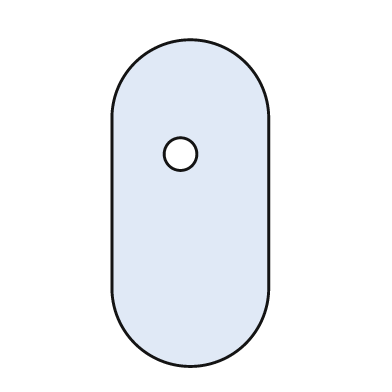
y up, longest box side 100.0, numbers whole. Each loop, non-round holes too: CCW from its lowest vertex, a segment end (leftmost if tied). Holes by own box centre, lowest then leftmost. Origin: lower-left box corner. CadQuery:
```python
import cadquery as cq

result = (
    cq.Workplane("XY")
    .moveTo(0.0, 24.0)
    .threePointArc((24.0, 0.0), (48.0, 24.0))
    .lineTo(48.0, 76.0)
    .threePointArc((24.0, 100.0), (0.0, 76.0))
    .close()
    .moveTo(21.0, 65.0)
    .circle(5.0)
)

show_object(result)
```